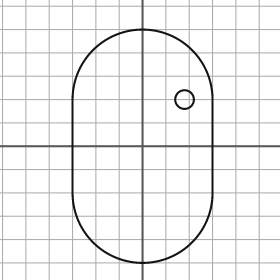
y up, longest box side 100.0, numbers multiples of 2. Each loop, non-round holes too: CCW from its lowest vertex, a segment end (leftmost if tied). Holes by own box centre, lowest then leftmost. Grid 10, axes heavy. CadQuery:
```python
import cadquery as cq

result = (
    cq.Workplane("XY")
    .moveTo(-30.0, -20.0)
    .threePointArc((0.0, -50.0), (30.0, -20.0))
    .lineTo(30.0, 20.0)
    .threePointArc((0.0, 50.0), (-30.0, 20.0))
    .close()
    .moveTo(18.0, 20.0)
    .circle(4.0)
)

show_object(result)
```